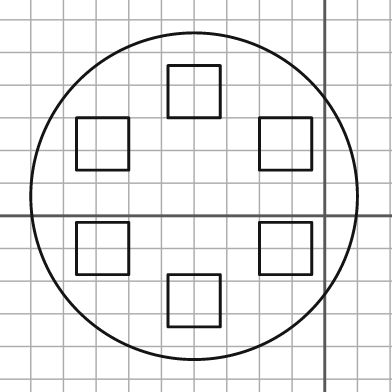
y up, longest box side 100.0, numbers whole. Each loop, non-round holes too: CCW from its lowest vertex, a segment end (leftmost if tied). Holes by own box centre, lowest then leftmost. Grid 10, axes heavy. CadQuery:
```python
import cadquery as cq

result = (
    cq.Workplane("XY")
    .moveTo(-40.0, 6.0)
    .circle(50.0)
    .moveTo(-48.0, -34.0)
    .lineTo(-32.0, -34.0)
    .lineTo(-32.0, -18.0)
    .lineTo(-48.0, -18.0)
    .close()
    .moveTo(-76.0, -18.0)
    .lineTo(-60.0, -18.0)
    .lineTo(-60.0, -2.0)
    .lineTo(-76.0, -2.0)
    .close()
    .moveTo(-20.0, -18.0)
    .lineTo(-4.0, -18.0)
    .lineTo(-4.0, -2.0)
    .lineTo(-20.0, -2.0)
    .close()
    .moveTo(-76.0, 14.0)
    .lineTo(-60.0, 14.0)
    .lineTo(-60.0, 30.0)
    .lineTo(-76.0, 30.0)
    .close()
    .moveTo(-20.0, 14.0)
    .lineTo(-4.0, 14.0)
    .lineTo(-4.0, 30.0)
    .lineTo(-20.0, 30.0)
    .close()
    .moveTo(-48.0, 30.0)
    .lineTo(-32.0, 30.0)
    .lineTo(-32.0, 46.0)
    .lineTo(-48.0, 46.0)
    .close()
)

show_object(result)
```